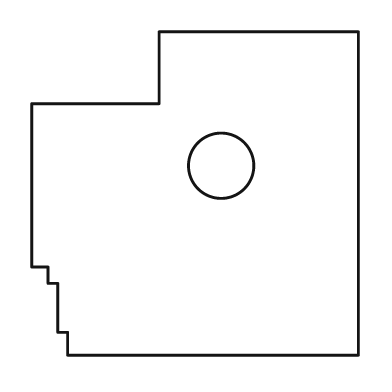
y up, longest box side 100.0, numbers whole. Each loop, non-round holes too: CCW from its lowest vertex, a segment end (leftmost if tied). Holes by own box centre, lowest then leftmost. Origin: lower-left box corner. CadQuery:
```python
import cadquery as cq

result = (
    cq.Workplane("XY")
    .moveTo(11.0, 0.0)
    .lineTo(100.0, 0.0)
    .lineTo(100.0, 99.0)
    .lineTo(39.0, 99.0)
    .lineTo(39.0, 77.0)
    .lineTo(0.0, 77.0)
    .lineTo(0.0, 27.0)
    .lineTo(5.0, 27.0)
    .lineTo(5.0, 22.0)
    .lineTo(8.0, 22.0)
    .lineTo(8.0, 7.0)
    .lineTo(11.0, 7.0)
    .close()
    .moveTo(58.0, 58.0)
    .circle(10.0)
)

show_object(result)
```